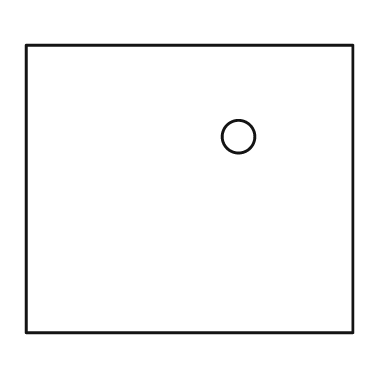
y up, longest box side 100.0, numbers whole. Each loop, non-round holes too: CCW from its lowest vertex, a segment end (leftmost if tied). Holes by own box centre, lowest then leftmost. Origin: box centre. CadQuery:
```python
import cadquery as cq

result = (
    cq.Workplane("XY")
    .moveTo(-50.0, -44.0)
    .lineTo(50.0, -44.0)
    .lineTo(50.0, 44.0)
    .lineTo(-50.0, 44.0)
    .close()
    .moveTo(15.0, 16.0)
    .circle(5.0)
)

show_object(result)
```